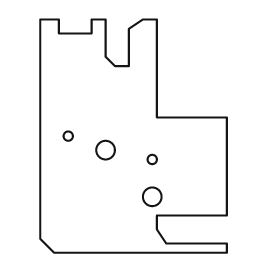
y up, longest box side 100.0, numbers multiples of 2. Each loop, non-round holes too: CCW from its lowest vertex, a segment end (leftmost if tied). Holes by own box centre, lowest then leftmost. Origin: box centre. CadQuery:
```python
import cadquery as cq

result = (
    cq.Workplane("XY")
    .moveTo(-34.0, -50.0)
    .lineTo(40.0, -50.0)
    .lineTo(40.0, -46.0)
    .lineTo(14.0, -46.0)
    .lineTo(10.0, -40.0)
    .lineTo(10.0, -34.0)
    .lineTo(40.0, -34.0)
    .lineTo(40.0, 8.0)
    .lineTo(10.0, 8.0)
    .lineTo(10.0, 50.0)
    .lineTo(4.0, 50.0)
    .lineTo(-2.0, 46.0)
    .lineTo(-2.0, 30.0)
    .lineTo(-8.0, 30.0)
    .lineTo(-12.0, 34.0)
    .lineTo(-12.0, 50.0)
    .lineTo(-18.0, 50.0)
    .lineTo(-18.0, 44.0)
    .lineTo(-32.0, 44.0)
    .lineTo(-32.0, 50.0)
    .lineTo(-40.0, 50.0)
    .lineTo(-40.0, -44.0)
    .close()
    .moveTo(8.0, -26.0)
    .circle(4.0)
    .moveTo(8.0, -10.0)
    .circle(2.0)
    .moveTo(-12.0, -6.0)
    .circle(4.0)
    .moveTo(-28.0, 0.0)
    .circle(2.0)
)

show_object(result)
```